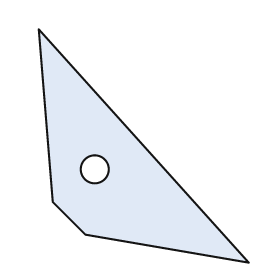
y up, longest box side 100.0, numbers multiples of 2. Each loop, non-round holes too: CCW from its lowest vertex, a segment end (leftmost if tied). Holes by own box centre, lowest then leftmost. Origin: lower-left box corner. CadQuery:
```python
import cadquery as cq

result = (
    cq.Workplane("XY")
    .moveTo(90.0, 0.0)
    .lineTo(0.0, 100.0)
    .lineTo(6.0, 26.0)
    .lineTo(20.0, 12.0)
    .close()
    .moveTo(24.0, 40.0)
    .circle(6.0)
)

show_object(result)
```